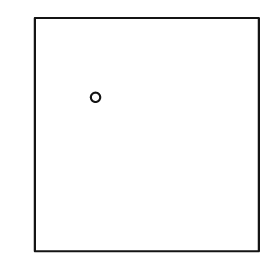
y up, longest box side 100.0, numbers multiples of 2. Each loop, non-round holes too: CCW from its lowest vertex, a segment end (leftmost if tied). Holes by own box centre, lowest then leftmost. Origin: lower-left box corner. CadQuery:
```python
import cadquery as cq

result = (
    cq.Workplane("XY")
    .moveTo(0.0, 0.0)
    .lineTo(96.0, 0.0)
    .lineTo(96.0, 100.0)
    .lineTo(0.0, 100.0)
    .close()
    .moveTo(26.0, 66.0)
    .circle(2.0)
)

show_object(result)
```